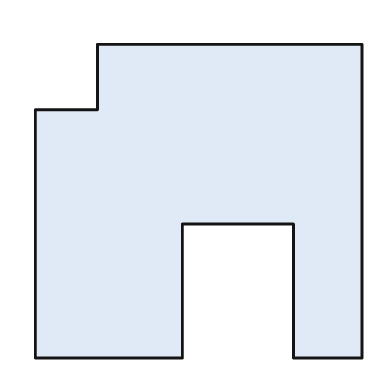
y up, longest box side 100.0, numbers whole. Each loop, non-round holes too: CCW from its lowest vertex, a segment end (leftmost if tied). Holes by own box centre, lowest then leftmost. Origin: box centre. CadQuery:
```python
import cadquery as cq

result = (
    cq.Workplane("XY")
    .moveTo(-50.0, -48.0)
    .lineTo(-5.0, -48.0)
    .lineTo(-5.0, -7.0)
    .lineTo(29.0, -7.0)
    .lineTo(29.0, -48.0)
    .lineTo(50.0, -48.0)
    .lineTo(50.0, 48.0)
    .lineTo(-31.0, 48.0)
    .lineTo(-31.0, 28.0)
    .lineTo(-50.0, 28.0)
    .close()
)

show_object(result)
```